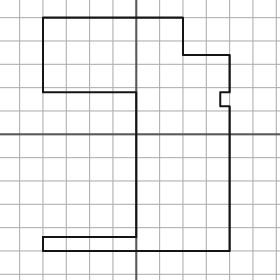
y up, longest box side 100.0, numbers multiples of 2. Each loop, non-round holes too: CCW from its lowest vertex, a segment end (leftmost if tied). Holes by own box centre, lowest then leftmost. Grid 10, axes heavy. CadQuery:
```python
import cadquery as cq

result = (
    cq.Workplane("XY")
    .moveTo(-40.0, -50.0)
    .lineTo(40.0, -50.0)
    .lineTo(40.0, 12.0)
    .lineTo(36.0, 12.0)
    .lineTo(36.0, 18.0)
    .lineTo(40.0, 18.0)
    .lineTo(40.0, 34.0)
    .lineTo(20.0, 34.0)
    .lineTo(20.0, 50.0)
    .lineTo(-40.0, 50.0)
    .lineTo(-40.0, 18.0)
    .lineTo(0.0, 18.0)
    .lineTo(0.0, -44.0)
    .lineTo(-40.0, -44.0)
    .close()
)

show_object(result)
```